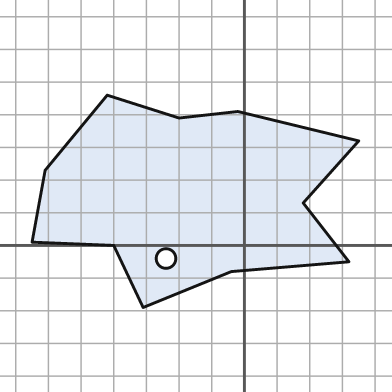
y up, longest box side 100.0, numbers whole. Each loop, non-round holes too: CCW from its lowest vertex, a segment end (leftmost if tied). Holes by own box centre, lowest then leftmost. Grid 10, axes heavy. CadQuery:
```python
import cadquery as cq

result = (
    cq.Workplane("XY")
    .moveTo(-31.0, -19.0)
    .lineTo(-4.0, -8.0)
    .lineTo(32.0, -5.0)
    .lineTo(18.0, 13.0)
    .lineTo(35.0, 32.0)
    .lineTo(-2.0, 41.0)
    .lineTo(-20.0, 39.0)
    .lineTo(-42.0, 46.0)
    .lineTo(-61.0, 23.0)
    .lineTo(-65.0, 1.0)
    .lineTo(-40.0, 0.0)
    .close()
    .moveTo(-24.0, -4.0)
    .circle(3.0)
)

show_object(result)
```